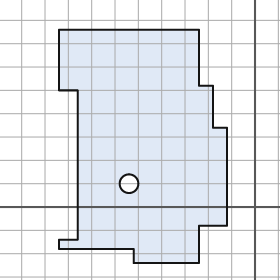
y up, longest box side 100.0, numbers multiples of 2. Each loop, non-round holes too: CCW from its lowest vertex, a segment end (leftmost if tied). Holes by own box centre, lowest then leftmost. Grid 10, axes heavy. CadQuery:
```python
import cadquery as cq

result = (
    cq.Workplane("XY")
    .moveTo(-52.0, -24.0)
    .lineTo(-24.0, -24.0)
    .lineTo(-24.0, -8.0)
    .lineTo(-12.0, -8.0)
    .lineTo(-12.0, 34.0)
    .lineTo(-18.0, 34.0)
    .lineTo(-18.0, 52.0)
    .lineTo(-24.0, 52.0)
    .lineTo(-24.0, 76.0)
    .lineTo(-84.0, 76.0)
    .lineTo(-84.0, 50.0)
    .lineTo(-76.0, 50.0)
    .lineTo(-76.0, -14.0)
    .lineTo(-84.0, -14.0)
    .lineTo(-84.0, -18.0)
    .lineTo(-52.0, -18.0)
    .close()
    .moveTo(-54.0, 10.0)
    .circle(4.0)
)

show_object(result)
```